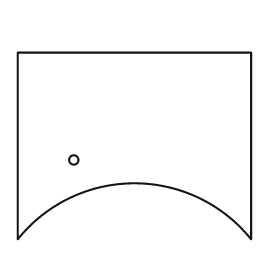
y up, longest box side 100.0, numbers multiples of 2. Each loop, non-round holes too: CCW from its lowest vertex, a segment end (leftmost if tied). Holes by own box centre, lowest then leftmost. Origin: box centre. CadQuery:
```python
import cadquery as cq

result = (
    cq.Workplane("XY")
    .moveTo(-50.0, -40.0)
    .threePointArc((0.0, -16.0), (50.0, -40.0))
    .lineTo(50.0, 40.0)
    .lineTo(-50.0, 40.0)
    .close()
    .moveTo(-26.0, -6.0)
    .circle(2.0)
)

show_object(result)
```